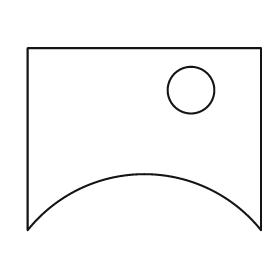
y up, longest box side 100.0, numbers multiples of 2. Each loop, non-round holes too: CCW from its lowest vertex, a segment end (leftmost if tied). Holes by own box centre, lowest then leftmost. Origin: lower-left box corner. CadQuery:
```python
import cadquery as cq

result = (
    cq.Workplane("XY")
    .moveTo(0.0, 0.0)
    .threePointArc((50.0, 24.0), (100.0, 0.0))
    .lineTo(100.0, 78.0)
    .lineTo(0.0, 78.0)
    .close()
    .moveTo(70.0, 60.0)
    .circle(10.0)
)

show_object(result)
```